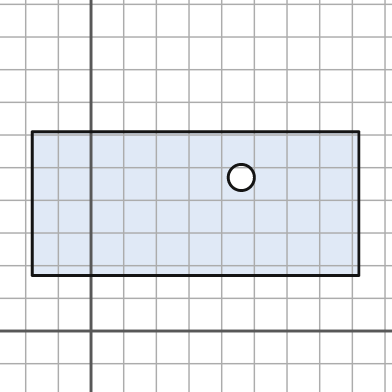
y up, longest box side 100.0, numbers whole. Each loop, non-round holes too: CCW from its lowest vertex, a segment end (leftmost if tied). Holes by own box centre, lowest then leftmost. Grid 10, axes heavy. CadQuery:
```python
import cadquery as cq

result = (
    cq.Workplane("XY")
    .moveTo(-18.0, 17.0)
    .lineTo(82.0, 17.0)
    .lineTo(82.0, 61.0)
    .lineTo(-18.0, 61.0)
    .close()
    .moveTo(46.0, 47.0)
    .circle(4.0)
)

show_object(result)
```